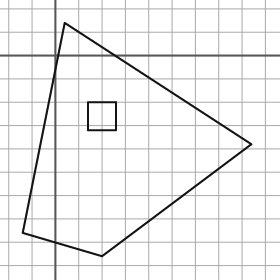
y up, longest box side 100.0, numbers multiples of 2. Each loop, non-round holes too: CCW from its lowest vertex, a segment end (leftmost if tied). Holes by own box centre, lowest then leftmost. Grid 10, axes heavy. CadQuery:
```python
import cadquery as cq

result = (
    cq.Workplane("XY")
    .moveTo(20.0, -86.0)
    .lineTo(84.0, -38.0)
    .lineTo(4.0, 14.0)
    .lineTo(-14.0, -76.0)
    .close()
    .moveTo(14.0, -32.0)
    .lineTo(26.0, -32.0)
    .lineTo(26.0, -20.0)
    .lineTo(14.0, -20.0)
    .close()
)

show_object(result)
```